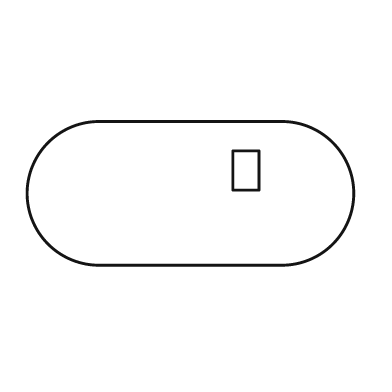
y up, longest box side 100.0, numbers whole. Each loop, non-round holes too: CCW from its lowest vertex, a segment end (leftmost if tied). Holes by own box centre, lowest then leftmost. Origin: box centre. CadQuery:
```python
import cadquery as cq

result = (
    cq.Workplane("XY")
    .moveTo(-28.0, -22.0)
    .lineTo(28.0, -22.0)
    .threePointArc((50.0, 0.0), (28.0, 22.0))
    .lineTo(-28.0, 22.0)
    .threePointArc((-50.0, 0.0), (-28.0, -22.0))
    .close()
    .moveTo(13.0, 1.0)
    .lineTo(21.0, 1.0)
    .lineTo(21.0, 13.0)
    .lineTo(13.0, 13.0)
    .close()
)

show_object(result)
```